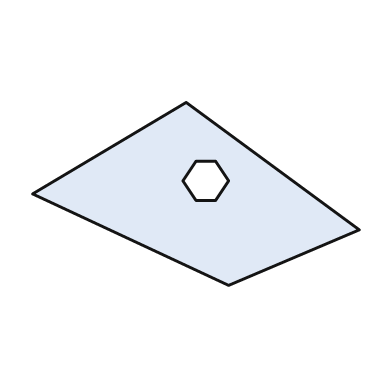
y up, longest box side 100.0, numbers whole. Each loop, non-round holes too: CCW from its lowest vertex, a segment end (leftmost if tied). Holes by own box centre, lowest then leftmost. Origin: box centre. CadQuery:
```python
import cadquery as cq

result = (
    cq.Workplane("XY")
    .moveTo(10.0, -28.0)
    .lineTo(50.0, -11.0)
    .lineTo(-3.0, 28.0)
    .lineTo(-50.0, 0.0)
    .close()
    .moveTo(0.0, -2.0)
    .lineTo(6.0, -2.0)
    .lineTo(10.0, 4.0)
    .lineTo(6.0, 10.0)
    .lineTo(0.0, 10.0)
    .lineTo(-4.0, 4.0)
    .close()
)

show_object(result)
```